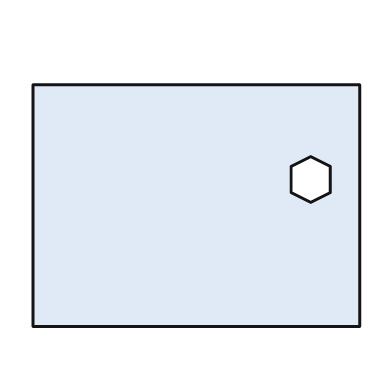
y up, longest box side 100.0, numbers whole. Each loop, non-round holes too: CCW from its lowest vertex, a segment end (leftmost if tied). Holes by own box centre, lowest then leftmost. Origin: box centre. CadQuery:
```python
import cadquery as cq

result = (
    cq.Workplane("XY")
    .moveTo(-50.0, -37.0)
    .lineTo(50.0, -37.0)
    .lineTo(50.0, 37.0)
    .lineTo(-50.0, 37.0)
    .close()
    .moveTo(35.0, 1.0)
    .lineTo(41.0, 4.0)
    .lineTo(41.0, 12.0)
    .lineTo(35.0, 15.0)
    .lineTo(29.0, 12.0)
    .lineTo(29.0, 4.0)
    .close()
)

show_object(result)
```